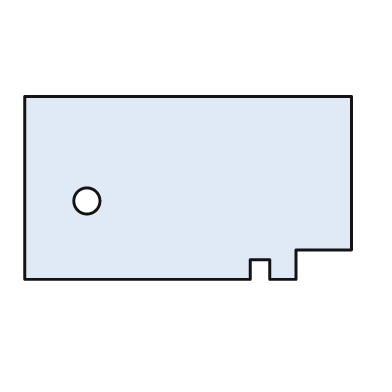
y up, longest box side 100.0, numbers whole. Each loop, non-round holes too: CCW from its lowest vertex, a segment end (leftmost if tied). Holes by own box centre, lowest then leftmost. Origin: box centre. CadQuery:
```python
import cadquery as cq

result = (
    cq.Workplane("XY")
    .moveTo(-50.0, -28.0)
    .lineTo(19.0, -28.0)
    .lineTo(19.0, -22.0)
    .lineTo(25.0, -22.0)
    .lineTo(25.0, -28.0)
    .lineTo(33.0, -28.0)
    .lineTo(33.0, -19.0)
    .lineTo(50.0, -19.0)
    .lineTo(50.0, 28.0)
    .lineTo(-50.0, 28.0)
    .close()
    .moveTo(-31.0, -4.0)
    .circle(4.0)
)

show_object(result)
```